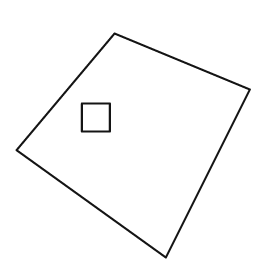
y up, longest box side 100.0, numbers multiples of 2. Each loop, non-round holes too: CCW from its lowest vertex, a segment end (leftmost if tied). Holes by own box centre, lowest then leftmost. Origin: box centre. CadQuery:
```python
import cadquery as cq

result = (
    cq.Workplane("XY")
    .moveTo(14.0, -48.0)
    .lineTo(50.0, 24.0)
    .lineTo(-8.0, 48.0)
    .lineTo(-50.0, -2.0)
    .close()
    .moveTo(-22.0, 6.0)
    .lineTo(-10.0, 6.0)
    .lineTo(-10.0, 18.0)
    .lineTo(-22.0, 18.0)
    .close()
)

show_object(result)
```